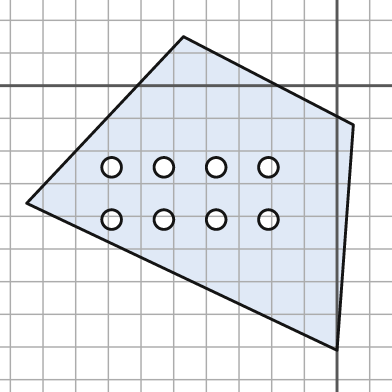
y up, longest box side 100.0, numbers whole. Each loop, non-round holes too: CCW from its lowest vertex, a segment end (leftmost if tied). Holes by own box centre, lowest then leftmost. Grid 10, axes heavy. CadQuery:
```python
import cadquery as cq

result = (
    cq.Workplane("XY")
    .moveTo(0.0, -81.0)
    .lineTo(5.0, -12.0)
    .lineTo(-47.0, 15.0)
    .lineTo(-95.0, -36.0)
    .close()
    .moveTo(-69.0, -41.0)
    .circle(3.0)
    .moveTo(-53.0, -41.0)
    .circle(3.0)
    .moveTo(-37.0, -41.0)
    .circle(3.0)
    .moveTo(-21.0, -41.0)
    .circle(3.0)
    .moveTo(-69.0, -25.0)
    .circle(3.0)
    .moveTo(-53.0, -25.0)
    .circle(3.0)
    .moveTo(-37.0, -25.0)
    .circle(3.0)
    .moveTo(-21.0, -25.0)
    .circle(3.0)
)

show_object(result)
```